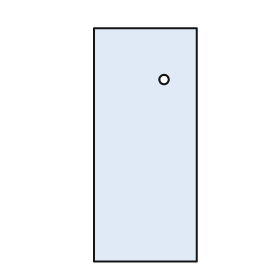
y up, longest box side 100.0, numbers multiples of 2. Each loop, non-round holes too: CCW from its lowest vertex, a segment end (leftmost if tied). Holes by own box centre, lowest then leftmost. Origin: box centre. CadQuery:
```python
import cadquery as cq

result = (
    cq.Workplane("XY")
    .moveTo(-22.0, -50.0)
    .lineTo(22.0, -50.0)
    .lineTo(22.0, 50.0)
    .lineTo(-22.0, 50.0)
    .close()
    .moveTo(8.0, 28.0)
    .circle(2.0)
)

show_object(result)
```